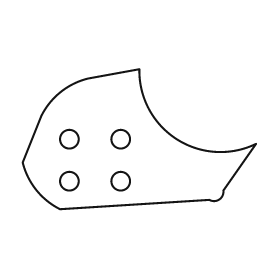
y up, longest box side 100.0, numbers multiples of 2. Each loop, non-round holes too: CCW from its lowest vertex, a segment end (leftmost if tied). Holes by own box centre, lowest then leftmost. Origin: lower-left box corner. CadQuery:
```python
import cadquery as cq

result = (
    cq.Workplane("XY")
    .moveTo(16.0, 0.0)
    .lineTo(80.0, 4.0)
    .threePointArc((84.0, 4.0), (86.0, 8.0))
    .lineTo(100.0, 28.0)
    .threePointArc((66.0, 30.0), (50.0, 60.0))
    .lineTo(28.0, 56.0)
    .threePointArc((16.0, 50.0), (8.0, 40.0))
    .lineTo(0.0, 20.0)
    .threePointArc((6.0, 8.0), (16.0, 0.0))
    .close()
    .moveTo(20.0, 12.0)
    .circle(4.0)
    .moveTo(42.0, 12.0)
    .circle(4.0)
    .moveTo(20.0, 30.0)
    .circle(4.0)
    .moveTo(42.0, 30.0)
    .circle(4.0)
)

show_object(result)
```